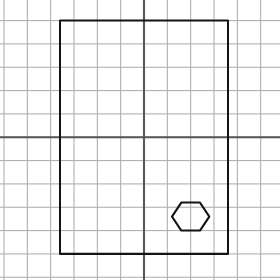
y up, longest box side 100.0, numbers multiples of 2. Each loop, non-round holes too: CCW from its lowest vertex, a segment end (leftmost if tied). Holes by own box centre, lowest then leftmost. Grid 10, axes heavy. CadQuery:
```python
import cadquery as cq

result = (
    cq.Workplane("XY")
    .moveTo(-36.0, -50.0)
    .lineTo(36.0, -50.0)
    .lineTo(36.0, 50.0)
    .lineTo(-36.0, 50.0)
    .close()
    .moveTo(16.0, -40.0)
    .lineTo(24.0, -40.0)
    .lineTo(28.0, -34.0)
    .lineTo(24.0, -28.0)
    .lineTo(16.0, -28.0)
    .lineTo(12.0, -34.0)
    .close()
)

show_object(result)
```